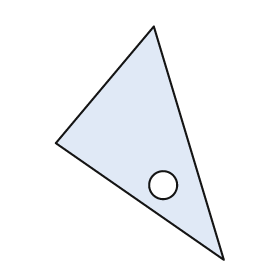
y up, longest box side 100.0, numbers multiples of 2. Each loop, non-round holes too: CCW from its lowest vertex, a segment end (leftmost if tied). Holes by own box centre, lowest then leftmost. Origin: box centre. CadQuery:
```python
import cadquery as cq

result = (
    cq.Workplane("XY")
    .moveTo(36.0, -50.0)
    .lineTo(6.0, 50.0)
    .lineTo(-36.0, 0.0)
    .close()
    .moveTo(10.0, -18.0)
    .circle(6.0)
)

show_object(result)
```